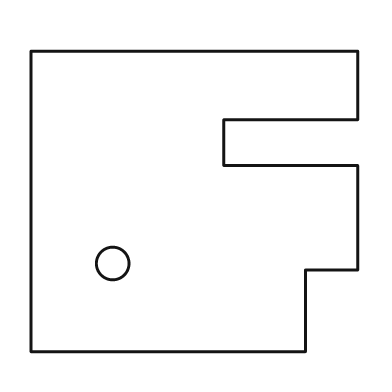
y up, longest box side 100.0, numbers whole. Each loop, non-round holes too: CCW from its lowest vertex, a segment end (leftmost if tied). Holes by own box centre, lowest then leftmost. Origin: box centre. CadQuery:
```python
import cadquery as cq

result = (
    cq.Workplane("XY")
    .moveTo(-50.0, -46.0)
    .lineTo(34.0, -46.0)
    .lineTo(34.0, -21.0)
    .lineTo(50.0, -21.0)
    .lineTo(50.0, 11.0)
    .lineTo(9.0, 11.0)
    .lineTo(9.0, 25.0)
    .lineTo(50.0, 25.0)
    .lineTo(50.0, 46.0)
    .lineTo(-50.0, 46.0)
    .close()
    .moveTo(-25.0, -19.0)
    .circle(5.0)
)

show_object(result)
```